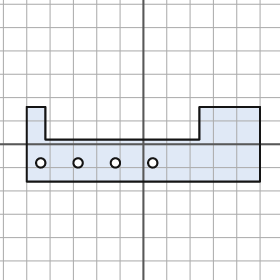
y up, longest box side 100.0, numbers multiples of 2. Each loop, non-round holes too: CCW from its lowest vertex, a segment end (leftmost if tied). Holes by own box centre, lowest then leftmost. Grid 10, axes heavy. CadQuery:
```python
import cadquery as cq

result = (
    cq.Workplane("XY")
    .moveTo(-50.0, -16.0)
    .lineTo(50.0, -16.0)
    .lineTo(50.0, 16.0)
    .lineTo(24.0, 16.0)
    .lineTo(24.0, 2.0)
    .lineTo(-42.0, 2.0)
    .lineTo(-42.0, 16.0)
    .lineTo(-50.0, 16.0)
    .close()
    .moveTo(-44.0, -8.0)
    .circle(2.0)
    .moveTo(-28.0, -8.0)
    .circle(2.0)
    .moveTo(-12.0, -8.0)
    .circle(2.0)
    .moveTo(4.0, -8.0)
    .circle(2.0)
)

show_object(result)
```